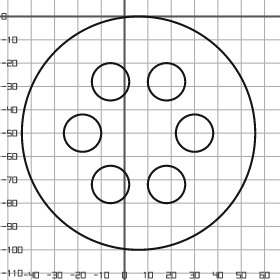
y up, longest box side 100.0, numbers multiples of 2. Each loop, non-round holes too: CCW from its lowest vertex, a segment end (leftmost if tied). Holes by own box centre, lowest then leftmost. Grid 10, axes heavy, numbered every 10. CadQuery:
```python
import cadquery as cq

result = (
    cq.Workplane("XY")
    .moveTo(6.0, -50.0)
    .circle(50.0)
    .moveTo(-6.0, -72.0)
    .circle(8.0)
    .moveTo(18.0, -72.0)
    .circle(8.0)
    .moveTo(-18.0, -50.0)
    .circle(8.0)
    .moveTo(30.0, -50.0)
    .circle(8.0)
    .moveTo(-6.0, -28.0)
    .circle(8.0)
    .moveTo(18.0, -28.0)
    .circle(8.0)
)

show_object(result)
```